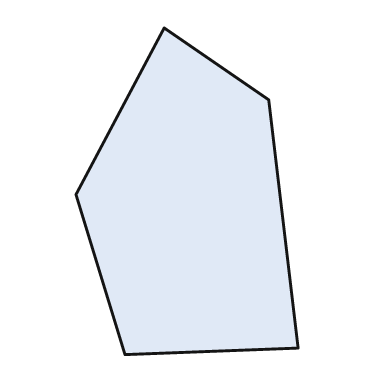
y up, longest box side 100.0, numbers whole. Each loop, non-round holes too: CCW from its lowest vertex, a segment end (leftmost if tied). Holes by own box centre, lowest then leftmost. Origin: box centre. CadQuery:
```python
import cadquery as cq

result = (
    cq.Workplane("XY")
    .moveTo(-19.0, -50.0)
    .lineTo(34.0, -48.0)
    .lineTo(25.0, 28.0)
    .lineTo(-7.0, 50.0)
    .lineTo(-34.0, -1.0)
    .close()
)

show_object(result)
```